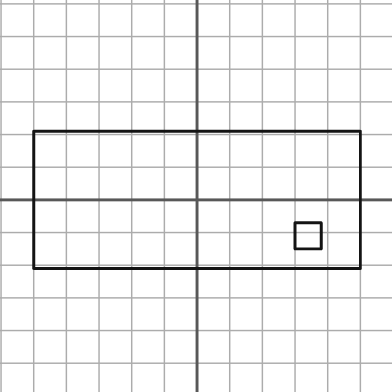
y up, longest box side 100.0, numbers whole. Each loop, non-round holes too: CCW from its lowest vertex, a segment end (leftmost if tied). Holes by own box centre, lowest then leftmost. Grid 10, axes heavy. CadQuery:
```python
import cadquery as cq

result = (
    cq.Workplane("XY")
    .moveTo(-50.0, -21.0)
    .lineTo(50.0, -21.0)
    .lineTo(50.0, 21.0)
    .lineTo(-50.0, 21.0)
    .close()
    .moveTo(30.0, -15.0)
    .lineTo(38.0, -15.0)
    .lineTo(38.0, -7.0)
    .lineTo(30.0, -7.0)
    .close()
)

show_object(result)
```